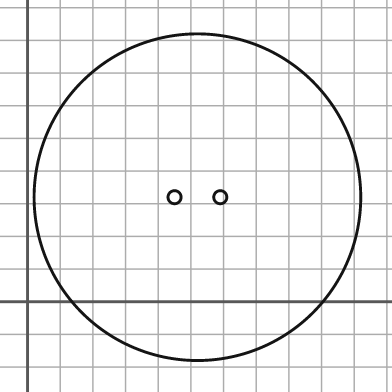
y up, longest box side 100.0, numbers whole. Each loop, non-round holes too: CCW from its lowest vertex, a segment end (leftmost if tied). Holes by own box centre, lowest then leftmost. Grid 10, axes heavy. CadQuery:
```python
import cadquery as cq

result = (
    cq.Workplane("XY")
    .moveTo(52.0, 32.0)
    .circle(50.0)
    .moveTo(45.0, 32.0)
    .circle(2.0)
    .moveTo(59.0, 32.0)
    .circle(2.0)
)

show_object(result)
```